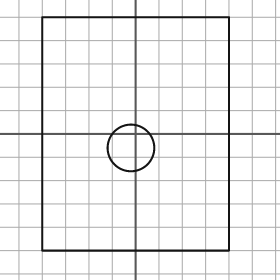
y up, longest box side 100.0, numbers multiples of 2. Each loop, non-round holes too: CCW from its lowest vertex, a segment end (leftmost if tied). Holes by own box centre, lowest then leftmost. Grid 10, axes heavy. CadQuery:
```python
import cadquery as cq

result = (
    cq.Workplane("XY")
    .moveTo(-40.0, -50.0)
    .lineTo(40.0, -50.0)
    .lineTo(40.0, 50.0)
    .lineTo(-40.0, 50.0)
    .close()
    .moveTo(-2.0, -6.0)
    .circle(10.0)
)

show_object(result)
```